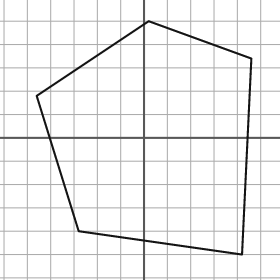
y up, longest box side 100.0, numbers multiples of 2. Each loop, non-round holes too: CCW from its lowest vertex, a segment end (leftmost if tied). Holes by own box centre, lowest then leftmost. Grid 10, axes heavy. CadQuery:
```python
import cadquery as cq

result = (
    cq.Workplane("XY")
    .moveTo(42.0, -50.0)
    .lineTo(46.0, 34.0)
    .lineTo(2.0, 50.0)
    .lineTo(-46.0, 18.0)
    .lineTo(-28.0, -40.0)
    .close()
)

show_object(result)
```